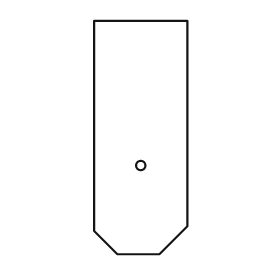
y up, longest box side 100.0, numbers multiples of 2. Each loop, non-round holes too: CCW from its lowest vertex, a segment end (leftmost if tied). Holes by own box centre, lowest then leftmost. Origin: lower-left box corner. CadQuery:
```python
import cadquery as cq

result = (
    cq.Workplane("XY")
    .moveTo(10.0, 0.0)
    .lineTo(28.0, 0.0)
    .lineTo(40.0, 12.0)
    .lineTo(40.0, 100.0)
    .lineTo(0.0, 100.0)
    .lineTo(0.0, 10.0)
    .close()
    .moveTo(20.0, 38.0)
    .circle(2.0)
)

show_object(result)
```